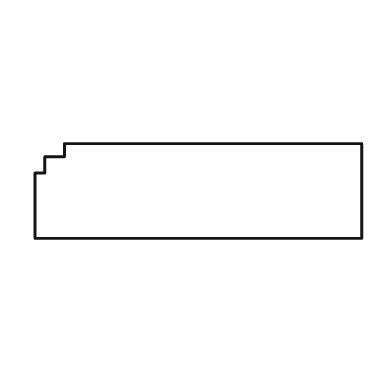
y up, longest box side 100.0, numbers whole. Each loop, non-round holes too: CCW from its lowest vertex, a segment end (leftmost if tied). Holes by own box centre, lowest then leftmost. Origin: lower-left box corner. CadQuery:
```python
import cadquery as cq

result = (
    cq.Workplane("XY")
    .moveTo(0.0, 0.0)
    .lineTo(100.0, 0.0)
    .lineTo(100.0, 29.0)
    .lineTo(9.0, 29.0)
    .lineTo(9.0, 25.0)
    .lineTo(3.0, 25.0)
    .lineTo(3.0, 20.0)
    .lineTo(0.0, 20.0)
    .close()
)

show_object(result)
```